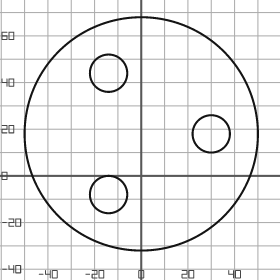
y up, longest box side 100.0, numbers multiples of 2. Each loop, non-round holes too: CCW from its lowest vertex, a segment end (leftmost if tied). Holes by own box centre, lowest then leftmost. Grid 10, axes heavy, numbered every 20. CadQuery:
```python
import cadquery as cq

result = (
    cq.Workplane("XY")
    .moveTo(0.0, 18.0)
    .circle(50.0)
    .moveTo(-14.0, -8.0)
    .circle(8.0)
    .moveTo(30.0, 18.0)
    .circle(8.0)
    .moveTo(-14.0, 44.0)
    .circle(8.0)
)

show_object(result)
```